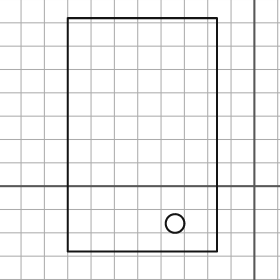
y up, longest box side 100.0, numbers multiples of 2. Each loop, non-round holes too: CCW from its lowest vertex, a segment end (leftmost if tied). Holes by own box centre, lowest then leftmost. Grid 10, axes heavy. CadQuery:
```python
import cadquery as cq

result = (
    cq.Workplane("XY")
    .moveTo(-80.0, -28.0)
    .lineTo(-16.0, -28.0)
    .lineTo(-16.0, 72.0)
    .lineTo(-80.0, 72.0)
    .close()
    .moveTo(-34.0, -16.0)
    .circle(4.0)
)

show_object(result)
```